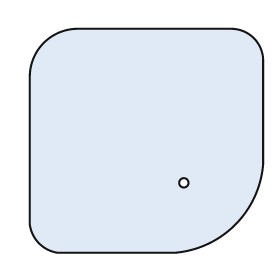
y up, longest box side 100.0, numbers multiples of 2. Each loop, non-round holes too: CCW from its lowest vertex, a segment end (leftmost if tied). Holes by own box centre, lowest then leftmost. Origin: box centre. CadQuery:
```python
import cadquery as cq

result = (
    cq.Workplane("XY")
    .moveTo(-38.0, -48.0)
    .lineTo(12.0, -48.0)
    .threePointArc((38.0, -36.0), (50.0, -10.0))
    .lineTo(50.0, 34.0)
    .threePointArc((46.0, 44.0), (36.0, 48.0))
    .lineTo(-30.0, 48.0)
    .threePointArc((-44.0, 42.0), (-50.0, 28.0))
    .lineTo(-50.0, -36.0)
    .threePointArc((-46.0, -44.0), (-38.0, -48.0))
    .close()
    .moveTo(16.0, -18.0)
    .circle(2.0)
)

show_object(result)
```